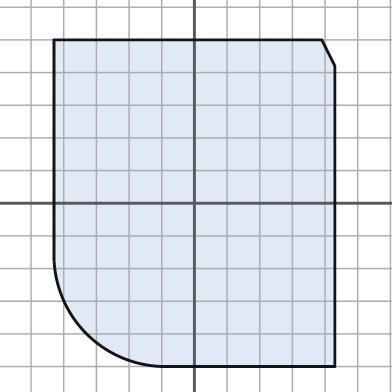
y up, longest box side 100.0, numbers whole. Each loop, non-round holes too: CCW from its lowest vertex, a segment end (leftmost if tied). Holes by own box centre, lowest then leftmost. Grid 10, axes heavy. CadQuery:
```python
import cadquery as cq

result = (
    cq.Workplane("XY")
    .moveTo(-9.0, -50.0)
    .lineTo(43.0, -50.0)
    .lineTo(43.0, 42.0)
    .lineTo(39.0, 50.0)
    .lineTo(-43.0, 50.0)
    .lineTo(-43.0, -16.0)
    .threePointArc((-33.0, -40.0), (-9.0, -50.0))
    .close()
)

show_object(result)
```